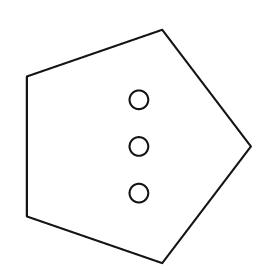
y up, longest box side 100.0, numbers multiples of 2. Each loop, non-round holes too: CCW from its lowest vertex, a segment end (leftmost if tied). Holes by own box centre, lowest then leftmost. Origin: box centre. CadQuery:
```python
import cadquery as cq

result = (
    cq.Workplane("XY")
    .moveTo(10.0, -50.0)
    .lineTo(48.0, 0.0)
    .lineTo(10.0, 50.0)
    .lineTo(-48.0, 30.0)
    .lineTo(-48.0, -30.0)
    .close()
    .moveTo(0.0, -20.0)
    .circle(4.0)
    .moveTo(0.0, 0.0)
    .circle(4.0)
    .moveTo(0.0, 20.0)
    .circle(4.0)
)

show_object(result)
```